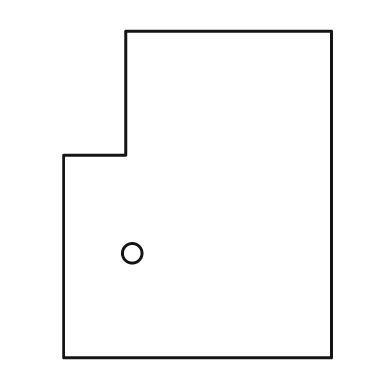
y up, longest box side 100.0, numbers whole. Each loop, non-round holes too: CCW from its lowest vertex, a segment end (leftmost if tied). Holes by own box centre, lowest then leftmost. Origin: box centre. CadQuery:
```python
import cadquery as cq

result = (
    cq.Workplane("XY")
    .moveTo(-41.0, -50.0)
    .lineTo(41.0, -50.0)
    .lineTo(41.0, 50.0)
    .lineTo(-22.0, 50.0)
    .lineTo(-22.0, 12.0)
    .lineTo(-41.0, 12.0)
    .close()
    .moveTo(-20.0, -18.0)
    .circle(3.0)
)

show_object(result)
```